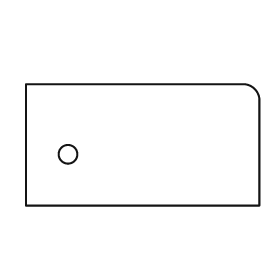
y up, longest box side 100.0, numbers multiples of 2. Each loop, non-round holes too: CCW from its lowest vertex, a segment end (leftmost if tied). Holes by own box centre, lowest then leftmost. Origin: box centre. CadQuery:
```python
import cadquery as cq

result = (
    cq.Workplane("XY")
    .moveTo(-50.0, -26.0)
    .lineTo(50.0, -26.0)
    .lineTo(50.0, 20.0)
    .threePointArc((48.0, 24.0), (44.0, 26.0))
    .lineTo(-50.0, 26.0)
    .close()
    .moveTo(-32.0, -4.0)
    .circle(4.0)
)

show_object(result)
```